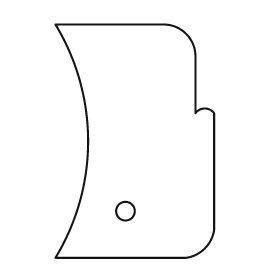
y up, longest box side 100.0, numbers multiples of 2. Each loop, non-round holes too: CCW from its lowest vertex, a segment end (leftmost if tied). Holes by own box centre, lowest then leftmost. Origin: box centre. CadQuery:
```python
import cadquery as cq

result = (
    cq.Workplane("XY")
    .moveTo(-34.0, -50.0)
    .lineTo(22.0, -50.0)
    .threePointArc((30.0, -46.0), (34.0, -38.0))
    .lineTo(34.0, 12.0)
    .threePointArc((30.0, 14.0), (26.0, 12.0))
    .lineTo(26.0, 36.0)
    .threePointArc((22.0, 46.0), (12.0, 50.0))
    .lineTo(-34.0, 50.0)
    .threePointArc((-20.0, 0.0), (-34.0, -50.0))
    .close()
    .moveTo(-4.0, -30.0)
    .circle(4.0)
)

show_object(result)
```